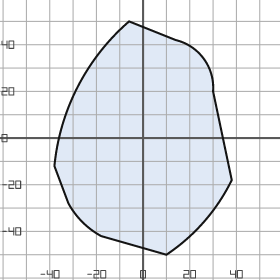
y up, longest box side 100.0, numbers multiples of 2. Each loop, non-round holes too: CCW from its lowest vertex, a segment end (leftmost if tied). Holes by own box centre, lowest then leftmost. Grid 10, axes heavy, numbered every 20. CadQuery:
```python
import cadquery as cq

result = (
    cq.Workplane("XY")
    .moveTo(10.0, -50.0)
    .threePointArc((26.0, -36.0), (38.0, -18.0))
    .lineTo(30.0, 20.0)
    .threePointArc((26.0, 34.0), (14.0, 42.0))
    .lineTo(-6.0, 50.0)
    .threePointArc((-28.0, 22.0), (-38.0, -12.0))
    .lineTo(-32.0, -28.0)
    .threePointArc((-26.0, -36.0), (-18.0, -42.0))
    .close()
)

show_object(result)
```